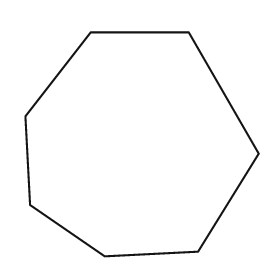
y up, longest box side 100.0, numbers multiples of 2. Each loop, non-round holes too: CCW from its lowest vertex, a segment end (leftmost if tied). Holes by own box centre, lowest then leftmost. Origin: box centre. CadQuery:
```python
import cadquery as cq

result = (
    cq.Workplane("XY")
    .moveTo(-16.0, -48.0)
    .lineTo(24.0, -46.0)
    .lineTo(50.0, -4.0)
    .lineTo(20.0, 48.0)
    .lineTo(-22.0, 48.0)
    .lineTo(-50.0, 12.0)
    .lineTo(-48.0, -26.0)
    .close()
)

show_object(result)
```